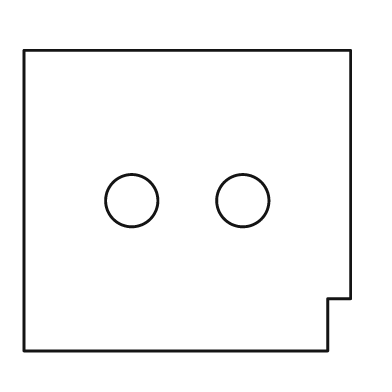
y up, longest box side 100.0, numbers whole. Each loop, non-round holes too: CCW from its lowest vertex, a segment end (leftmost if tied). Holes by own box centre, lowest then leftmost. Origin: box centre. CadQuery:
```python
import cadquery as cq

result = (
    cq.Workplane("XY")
    .moveTo(-50.0, -46.0)
    .lineTo(43.0, -46.0)
    .lineTo(43.0, -30.0)
    .lineTo(50.0, -30.0)
    .lineTo(50.0, 46.0)
    .lineTo(-50.0, 46.0)
    .close()
    .moveTo(-17.0, 0.0)
    .circle(8.0)
    .moveTo(17.0, 0.0)
    .circle(8.0)
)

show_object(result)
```